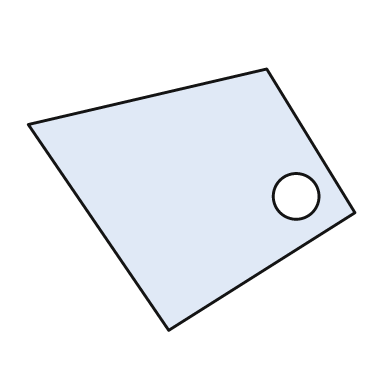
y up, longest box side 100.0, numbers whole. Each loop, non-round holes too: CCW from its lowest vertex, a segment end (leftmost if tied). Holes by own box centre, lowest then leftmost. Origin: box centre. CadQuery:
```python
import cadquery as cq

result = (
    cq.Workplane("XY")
    .moveTo(-7.0, -40.0)
    .lineTo(50.0, -4.0)
    .lineTo(23.0, 40.0)
    .lineTo(-50.0, 23.0)
    .close()
    .moveTo(32.0, 1.0)
    .circle(7.0)
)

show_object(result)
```